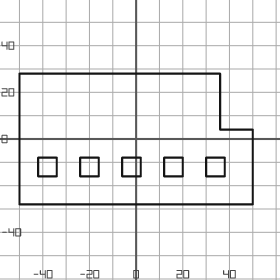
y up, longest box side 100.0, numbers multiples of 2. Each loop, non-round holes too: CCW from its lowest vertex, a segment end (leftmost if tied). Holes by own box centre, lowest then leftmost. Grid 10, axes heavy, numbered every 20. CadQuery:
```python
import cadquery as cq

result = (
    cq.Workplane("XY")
    .moveTo(-50.0, -28.0)
    .lineTo(50.0, -28.0)
    .lineTo(50.0, 4.0)
    .lineTo(36.0, 4.0)
    .lineTo(36.0, 28.0)
    .lineTo(-50.0, 28.0)
    .close()
    .moveTo(-42.0, -16.0)
    .lineTo(-34.0, -16.0)
    .lineTo(-34.0, -8.0)
    .lineTo(-42.0, -8.0)
    .close()
    .moveTo(-24.0, -16.0)
    .lineTo(-16.0, -16.0)
    .lineTo(-16.0, -8.0)
    .lineTo(-24.0, -8.0)
    .close()
    .moveTo(-6.0, -16.0)
    .lineTo(2.0, -16.0)
    .lineTo(2.0, -8.0)
    .lineTo(-6.0, -8.0)
    .close()
    .moveTo(12.0, -16.0)
    .lineTo(20.0, -16.0)
    .lineTo(20.0, -8.0)
    .lineTo(12.0, -8.0)
    .close()
    .moveTo(30.0, -16.0)
    .lineTo(38.0, -16.0)
    .lineTo(38.0, -8.0)
    .lineTo(30.0, -8.0)
    .close()
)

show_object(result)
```